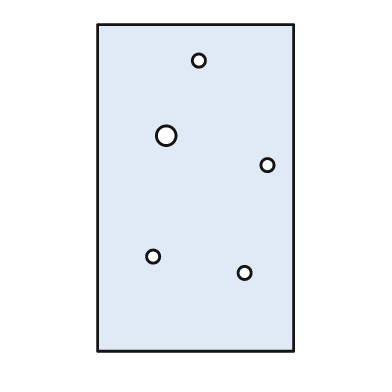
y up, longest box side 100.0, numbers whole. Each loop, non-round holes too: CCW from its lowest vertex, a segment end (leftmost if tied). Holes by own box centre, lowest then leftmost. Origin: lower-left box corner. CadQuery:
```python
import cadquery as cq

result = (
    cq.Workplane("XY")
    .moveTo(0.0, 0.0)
    .lineTo(60.0, 0.0)
    .lineTo(60.0, 100.0)
    .lineTo(0.0, 100.0)
    .close()
    .moveTo(45.0, 24.0)
    .circle(2.0)
    .moveTo(17.0, 29.0)
    .circle(2.0)
    .moveTo(52.0, 57.0)
    .circle(2.0)
    .moveTo(21.0, 66.0)
    .circle(3.0)
    .moveTo(31.0, 89.0)
    .circle(2.0)
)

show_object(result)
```